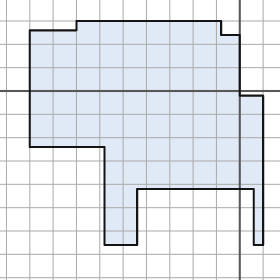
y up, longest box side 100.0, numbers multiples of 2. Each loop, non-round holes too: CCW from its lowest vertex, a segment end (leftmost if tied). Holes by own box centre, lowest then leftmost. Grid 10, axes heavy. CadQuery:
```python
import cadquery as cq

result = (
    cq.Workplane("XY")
    .moveTo(-58.0, -66.0)
    .lineTo(-44.0, -66.0)
    .lineTo(-44.0, -42.0)
    .lineTo(6.0, -42.0)
    .lineTo(6.0, -66.0)
    .lineTo(10.0, -66.0)
    .lineTo(10.0, -2.0)
    .lineTo(0.0, -2.0)
    .lineTo(0.0, 24.0)
    .lineTo(-8.0, 24.0)
    .lineTo(-8.0, 30.0)
    .lineTo(-70.0, 30.0)
    .lineTo(-70.0, 26.0)
    .lineTo(-90.0, 26.0)
    .lineTo(-90.0, -24.0)
    .lineTo(-58.0, -24.0)
    .close()
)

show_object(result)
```